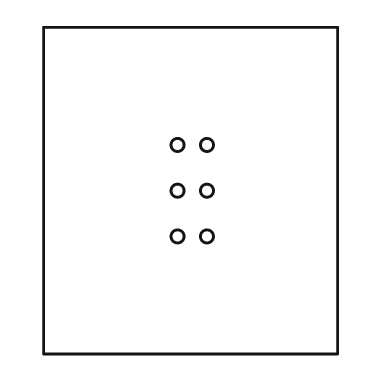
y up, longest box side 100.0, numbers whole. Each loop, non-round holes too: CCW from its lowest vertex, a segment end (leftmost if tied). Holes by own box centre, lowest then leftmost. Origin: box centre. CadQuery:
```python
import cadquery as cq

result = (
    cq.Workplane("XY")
    .moveTo(-45.0, -50.0)
    .lineTo(45.0, -50.0)
    .lineTo(45.0, 50.0)
    .lineTo(-45.0, 50.0)
    .close()
    .moveTo(-4.0, -14.0)
    .circle(2.0)
    .moveTo(5.0, -14.0)
    .circle(2.0)
    .moveTo(-4.0, 0.0)
    .circle(2.0)
    .moveTo(5.0, 0.0)
    .circle(2.0)
    .moveTo(-4.0, 14.0)
    .circle(2.0)
    .moveTo(5.0, 14.0)
    .circle(2.0)
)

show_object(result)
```